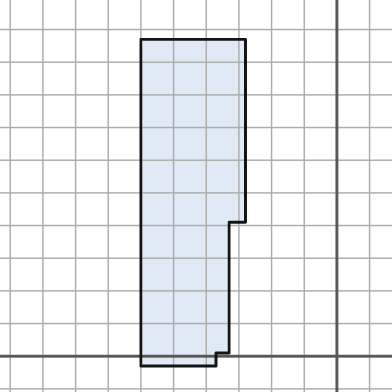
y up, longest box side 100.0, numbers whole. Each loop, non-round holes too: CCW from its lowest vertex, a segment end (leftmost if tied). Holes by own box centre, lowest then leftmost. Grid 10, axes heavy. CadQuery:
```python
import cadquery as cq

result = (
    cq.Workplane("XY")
    .moveTo(-60.0, -3.0)
    .lineTo(-37.0, -3.0)
    .lineTo(-37.0, 1.0)
    .lineTo(-33.0, 1.0)
    .lineTo(-33.0, 41.0)
    .lineTo(-28.0, 41.0)
    .lineTo(-28.0, 97.0)
    .lineTo(-60.0, 97.0)
    .close()
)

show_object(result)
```